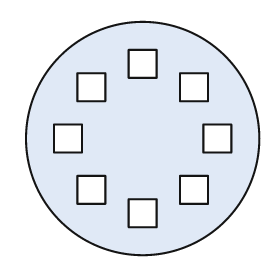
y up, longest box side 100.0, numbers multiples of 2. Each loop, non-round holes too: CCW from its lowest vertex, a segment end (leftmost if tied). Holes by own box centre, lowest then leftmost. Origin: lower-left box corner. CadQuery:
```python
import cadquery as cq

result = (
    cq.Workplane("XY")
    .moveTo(50.0, 50.0)
    .circle(50.0)
    .moveTo(44.0, 12.0)
    .lineTo(56.0, 12.0)
    .lineTo(56.0, 24.0)
    .lineTo(44.0, 24.0)
    .close()
    .moveTo(22.0, 22.0)
    .lineTo(34.0, 22.0)
    .lineTo(34.0, 34.0)
    .lineTo(22.0, 34.0)
    .close()
    .moveTo(66.0, 22.0)
    .lineTo(78.0, 22.0)
    .lineTo(78.0, 34.0)
    .lineTo(66.0, 34.0)
    .close()
    .moveTo(12.0, 44.0)
    .lineTo(24.0, 44.0)
    .lineTo(24.0, 56.0)
    .lineTo(12.0, 56.0)
    .close()
    .moveTo(76.0, 44.0)
    .lineTo(88.0, 44.0)
    .lineTo(88.0, 56.0)
    .lineTo(76.0, 56.0)
    .close()
    .moveTo(22.0, 66.0)
    .lineTo(34.0, 66.0)
    .lineTo(34.0, 78.0)
    .lineTo(22.0, 78.0)
    .close()
    .moveTo(66.0, 66.0)
    .lineTo(78.0, 66.0)
    .lineTo(78.0, 78.0)
    .lineTo(66.0, 78.0)
    .close()
    .moveTo(44.0, 76.0)
    .lineTo(56.0, 76.0)
    .lineTo(56.0, 88.0)
    .lineTo(44.0, 88.0)
    .close()
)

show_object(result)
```